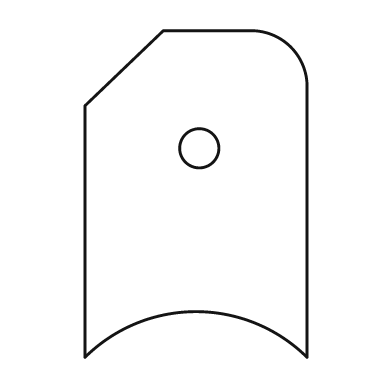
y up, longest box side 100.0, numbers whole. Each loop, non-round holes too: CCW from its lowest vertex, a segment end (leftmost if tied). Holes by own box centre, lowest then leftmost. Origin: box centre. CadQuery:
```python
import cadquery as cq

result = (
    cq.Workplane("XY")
    .moveTo(-34.0, -50.0)
    .threePointArc((0.0, -36.0), (34.0, -50.0))
    .lineTo(34.0, 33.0)
    .threePointArc((29.0, 45.0), (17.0, 50.0))
    .lineTo(-10.0, 50.0)
    .lineTo(-34.0, 27.0)
    .close()
    .moveTo(1.0, 14.0)
    .circle(6.0)
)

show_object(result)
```